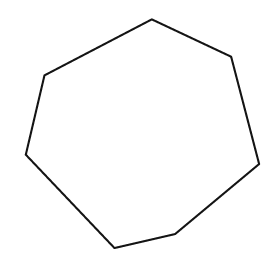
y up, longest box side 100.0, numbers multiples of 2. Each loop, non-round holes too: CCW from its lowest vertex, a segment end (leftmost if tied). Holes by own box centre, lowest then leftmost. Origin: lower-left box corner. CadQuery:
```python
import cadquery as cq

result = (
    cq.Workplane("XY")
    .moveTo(38.0, 0.0)
    .lineTo(64.0, 6.0)
    .lineTo(100.0, 36.0)
    .lineTo(88.0, 82.0)
    .lineTo(54.0, 98.0)
    .lineTo(8.0, 74.0)
    .lineTo(0.0, 40.0)
    .close()
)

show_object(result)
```